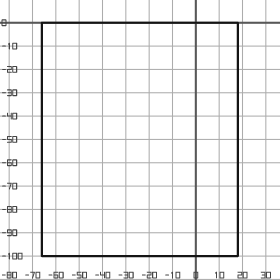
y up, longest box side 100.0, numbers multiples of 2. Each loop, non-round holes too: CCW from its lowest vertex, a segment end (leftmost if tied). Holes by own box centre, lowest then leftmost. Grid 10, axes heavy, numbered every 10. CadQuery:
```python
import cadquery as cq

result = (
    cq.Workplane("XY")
    .moveTo(-66.0, -100.0)
    .lineTo(18.0, -100.0)
    .lineTo(18.0, 0.0)
    .lineTo(-66.0, 0.0)
    .close()
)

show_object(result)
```